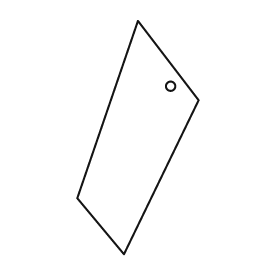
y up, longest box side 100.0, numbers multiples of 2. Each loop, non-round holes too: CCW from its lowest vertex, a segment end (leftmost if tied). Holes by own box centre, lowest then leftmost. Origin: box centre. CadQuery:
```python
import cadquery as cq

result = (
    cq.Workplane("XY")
    .moveTo(-6.0, -50.0)
    .lineTo(26.0, 16.0)
    .lineTo(0.0, 50.0)
    .lineTo(-26.0, -26.0)
    .close()
    .moveTo(14.0, 22.0)
    .circle(2.0)
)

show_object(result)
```